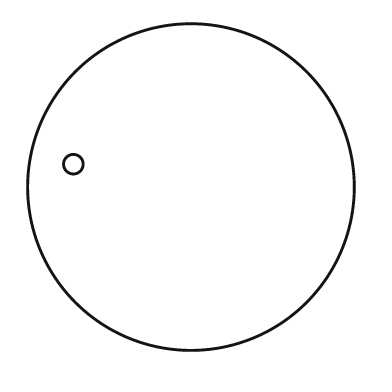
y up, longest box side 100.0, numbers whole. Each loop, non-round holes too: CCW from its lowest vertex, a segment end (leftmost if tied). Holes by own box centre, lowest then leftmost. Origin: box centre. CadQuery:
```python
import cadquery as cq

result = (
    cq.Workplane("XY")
    .moveTo(0.0, 0.0)
    .circle(50.0)
    .moveTo(-36.0, 7.0)
    .circle(3.0)
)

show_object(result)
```